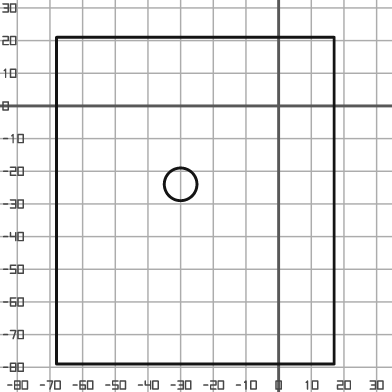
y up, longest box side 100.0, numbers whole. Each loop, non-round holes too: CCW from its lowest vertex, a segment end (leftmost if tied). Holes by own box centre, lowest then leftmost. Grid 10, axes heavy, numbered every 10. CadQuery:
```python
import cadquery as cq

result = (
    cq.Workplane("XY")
    .moveTo(-68.0, -79.0)
    .lineTo(17.0, -79.0)
    .lineTo(17.0, 21.0)
    .lineTo(-68.0, 21.0)
    .close()
    .moveTo(-30.0, -24.0)
    .circle(5.0)
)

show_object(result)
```